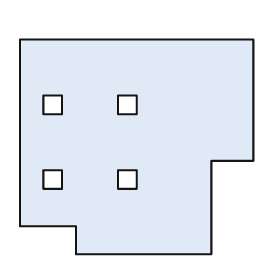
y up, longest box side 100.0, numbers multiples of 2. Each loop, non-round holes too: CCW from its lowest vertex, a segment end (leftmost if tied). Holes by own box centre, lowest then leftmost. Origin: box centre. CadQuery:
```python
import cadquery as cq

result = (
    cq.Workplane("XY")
    .moveTo(-26.0, -46.0)
    .lineTo(32.0, -46.0)
    .lineTo(32.0, -6.0)
    .lineTo(50.0, -6.0)
    .lineTo(50.0, 46.0)
    .lineTo(-50.0, 46.0)
    .lineTo(-50.0, -34.0)
    .lineTo(-26.0, -34.0)
    .close()
    .moveTo(-40.0, -18.0)
    .lineTo(-32.0, -18.0)
    .lineTo(-32.0, -10.0)
    .lineTo(-40.0, -10.0)
    .close()
    .moveTo(-8.0, -18.0)
    .lineTo(0.0, -18.0)
    .lineTo(0.0, -10.0)
    .lineTo(-8.0, -10.0)
    .close()
    .moveTo(-40.0, 14.0)
    .lineTo(-32.0, 14.0)
    .lineTo(-32.0, 22.0)
    .lineTo(-40.0, 22.0)
    .close()
    .moveTo(-8.0, 14.0)
    .lineTo(0.0, 14.0)
    .lineTo(0.0, 22.0)
    .lineTo(-8.0, 22.0)
    .close()
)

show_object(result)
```